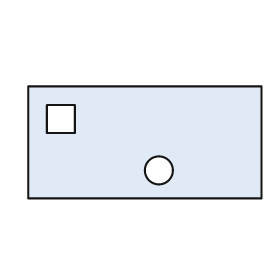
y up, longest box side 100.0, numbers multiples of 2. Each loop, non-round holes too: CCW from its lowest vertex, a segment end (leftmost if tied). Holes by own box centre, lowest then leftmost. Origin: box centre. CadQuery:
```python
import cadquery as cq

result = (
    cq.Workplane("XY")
    .moveTo(-50.0, -24.0)
    .lineTo(50.0, -24.0)
    .lineTo(50.0, 24.0)
    .lineTo(-50.0, 24.0)
    .close()
    .moveTo(6.0, -12.0)
    .circle(6.0)
    .moveTo(-42.0, 4.0)
    .lineTo(-30.0, 4.0)
    .lineTo(-30.0, 16.0)
    .lineTo(-42.0, 16.0)
    .close()
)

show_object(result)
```